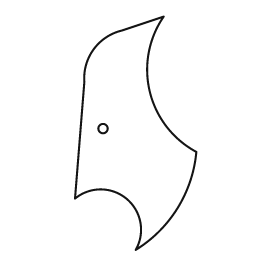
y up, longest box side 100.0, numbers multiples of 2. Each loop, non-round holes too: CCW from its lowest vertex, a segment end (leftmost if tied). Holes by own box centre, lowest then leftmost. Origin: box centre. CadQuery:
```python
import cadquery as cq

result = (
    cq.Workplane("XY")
    .moveTo(0.0, -50.0)
    .threePointArc((18.0, -32.0), (26.0, -8.0))
    .threePointArc((6.0, 18.0), (12.0, 50.0))
    .lineTo(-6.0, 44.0)
    .threePointArc((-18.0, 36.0), (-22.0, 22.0))
    .lineTo(-26.0, -28.0)
    .threePointArc((-4.0, -28.0), (0.0, -50.0))
    .close()
    .moveTo(-14.0, 2.0)
    .circle(2.0)
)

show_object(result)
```